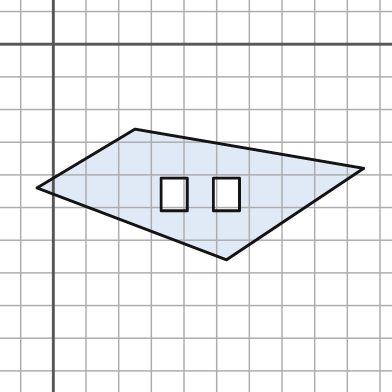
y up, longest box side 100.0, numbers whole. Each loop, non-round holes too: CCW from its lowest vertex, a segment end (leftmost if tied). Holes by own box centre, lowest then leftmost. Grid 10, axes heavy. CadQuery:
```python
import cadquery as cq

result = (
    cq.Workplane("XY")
    .moveTo(53.0, -66.0)
    .lineTo(95.0, -38.0)
    .lineTo(25.0, -26.0)
    .lineTo(-5.0, -44.0)
    .close()
    .moveTo(33.0, -51.0)
    .lineTo(41.0, -51.0)
    .lineTo(41.0, -41.0)
    .lineTo(33.0, -41.0)
    .close()
    .moveTo(49.0, -51.0)
    .lineTo(57.0, -51.0)
    .lineTo(57.0, -41.0)
    .lineTo(49.0, -41.0)
    .close()
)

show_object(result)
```